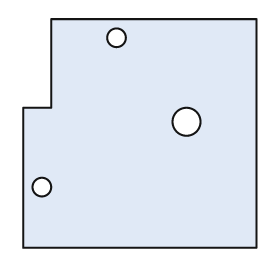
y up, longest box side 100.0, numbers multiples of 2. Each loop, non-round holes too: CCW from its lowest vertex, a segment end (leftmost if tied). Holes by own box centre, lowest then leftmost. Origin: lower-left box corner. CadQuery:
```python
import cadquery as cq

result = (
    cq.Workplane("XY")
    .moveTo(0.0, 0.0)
    .lineTo(100.0, 0.0)
    .lineTo(100.0, 98.0)
    .lineTo(12.0, 98.0)
    .lineTo(12.0, 60.0)
    .lineTo(0.0, 60.0)
    .close()
    .moveTo(8.0, 26.0)
    .circle(4.0)
    .moveTo(70.0, 54.0)
    .circle(6.0)
    .moveTo(40.0, 90.0)
    .circle(4.0)
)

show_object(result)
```